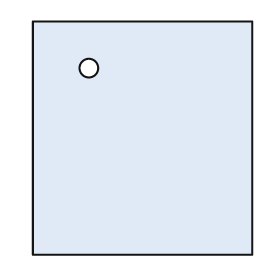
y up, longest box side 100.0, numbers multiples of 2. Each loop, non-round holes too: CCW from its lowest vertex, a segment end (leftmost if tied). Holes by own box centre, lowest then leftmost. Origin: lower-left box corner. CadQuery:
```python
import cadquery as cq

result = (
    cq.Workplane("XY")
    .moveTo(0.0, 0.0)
    .lineTo(94.0, 0.0)
    .lineTo(94.0, 100.0)
    .lineTo(0.0, 100.0)
    .close()
    .moveTo(24.0, 80.0)
    .circle(4.0)
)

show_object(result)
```